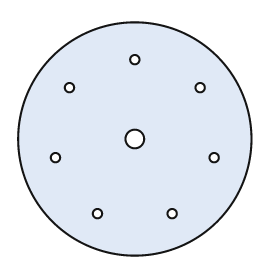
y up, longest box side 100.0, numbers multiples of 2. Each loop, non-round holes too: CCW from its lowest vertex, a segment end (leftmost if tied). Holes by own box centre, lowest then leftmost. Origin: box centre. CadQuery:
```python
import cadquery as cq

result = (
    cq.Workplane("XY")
    .moveTo(0.0, 0.0)
    .circle(50.0)
    .moveTo(-16.0, -32.0)
    .circle(2.0)
    .moveTo(16.0, -32.0)
    .circle(2.0)
    .moveTo(-34.0, -8.0)
    .circle(2.0)
    .moveTo(34.0, -8.0)
    .circle(2.0)
    .moveTo(0.0, 0.0)
    .circle(4.0)
    .moveTo(-28.0, 22.0)
    .circle(2.0)
    .moveTo(28.0, 22.0)
    .circle(2.0)
    .moveTo(0.0, 34.0)
    .circle(2.0)
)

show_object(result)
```